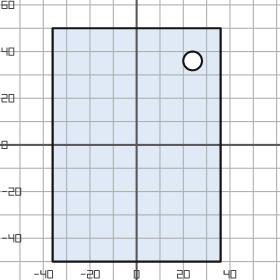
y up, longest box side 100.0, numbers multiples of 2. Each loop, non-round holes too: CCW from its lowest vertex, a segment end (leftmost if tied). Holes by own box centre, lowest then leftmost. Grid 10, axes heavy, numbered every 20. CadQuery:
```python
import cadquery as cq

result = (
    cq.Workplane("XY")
    .moveTo(-36.0, -50.0)
    .lineTo(36.0, -50.0)
    .lineTo(36.0, 50.0)
    .lineTo(-36.0, 50.0)
    .close()
    .moveTo(24.0, 36.0)
    .circle(4.0)
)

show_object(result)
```